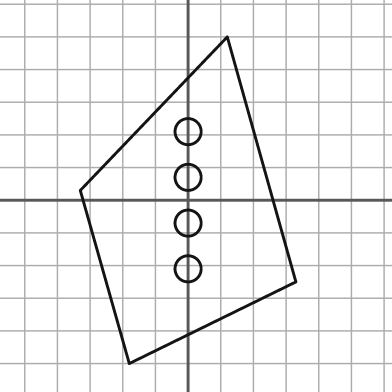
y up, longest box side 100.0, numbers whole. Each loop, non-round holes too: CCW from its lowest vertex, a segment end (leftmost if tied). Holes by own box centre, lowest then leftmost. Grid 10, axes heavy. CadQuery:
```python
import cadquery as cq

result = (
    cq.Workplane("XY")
    .moveTo(-18.0, -50.0)
    .lineTo(33.0, -25.0)
    .lineTo(12.0, 50.0)
    .lineTo(-33.0, 3.0)
    .close()
    .moveTo(0.0, -21.0)
    .circle(4.0)
    .moveTo(0.0, -7.0)
    .circle(4.0)
    .moveTo(0.0, 7.0)
    .circle(4.0)
    .moveTo(0.0, 21.0)
    .circle(4.0)
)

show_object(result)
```